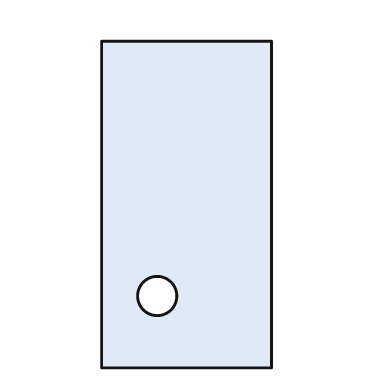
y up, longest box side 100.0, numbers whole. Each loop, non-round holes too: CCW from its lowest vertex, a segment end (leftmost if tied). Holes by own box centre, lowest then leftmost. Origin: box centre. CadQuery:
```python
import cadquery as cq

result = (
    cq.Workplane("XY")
    .moveTo(-26.0, -50.0)
    .lineTo(26.0, -50.0)
    .lineTo(26.0, 50.0)
    .lineTo(-26.0, 50.0)
    .close()
    .moveTo(-9.0, -28.0)
    .circle(6.0)
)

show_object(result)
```